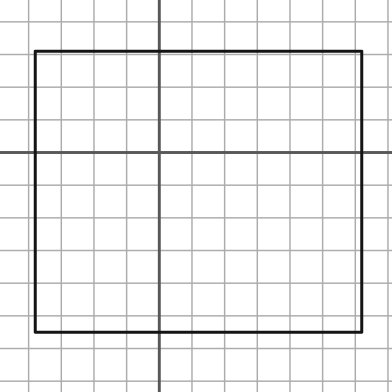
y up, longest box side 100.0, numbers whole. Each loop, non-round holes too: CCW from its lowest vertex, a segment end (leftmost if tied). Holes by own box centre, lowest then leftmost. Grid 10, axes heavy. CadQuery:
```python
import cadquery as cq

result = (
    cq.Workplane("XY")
    .moveTo(-38.0, -55.0)
    .lineTo(62.0, -55.0)
    .lineTo(62.0, 31.0)
    .lineTo(-38.0, 31.0)
    .close()
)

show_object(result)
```